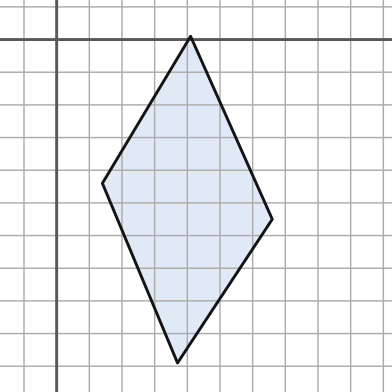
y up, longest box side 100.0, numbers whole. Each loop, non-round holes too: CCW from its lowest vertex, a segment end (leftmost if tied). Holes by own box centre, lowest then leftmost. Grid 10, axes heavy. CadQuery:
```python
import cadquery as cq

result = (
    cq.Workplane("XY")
    .moveTo(37.0, -99.0)
    .lineTo(66.0, -55.0)
    .lineTo(41.0, 1.0)
    .lineTo(14.0, -44.0)
    .close()
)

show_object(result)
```